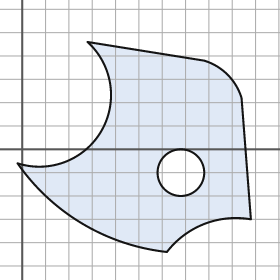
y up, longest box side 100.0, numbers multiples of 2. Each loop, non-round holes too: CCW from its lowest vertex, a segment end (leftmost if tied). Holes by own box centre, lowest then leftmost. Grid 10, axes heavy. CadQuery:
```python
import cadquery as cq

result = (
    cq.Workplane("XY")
    .moveTo(62.0, -44.0)
    .threePointArc((78.0, -32.0), (98.0, -30.0))
    .lineTo(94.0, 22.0)
    .threePointArc((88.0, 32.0), (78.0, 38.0))
    .lineTo(28.0, 46.0)
    .threePointArc((34.0, 8.0), (-2.0, -6.0))
    .threePointArc((26.0, -32.0), (62.0, -44.0))
    .close()
    .moveTo(68.0, -10.0)
    .circle(10.0)
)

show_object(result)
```